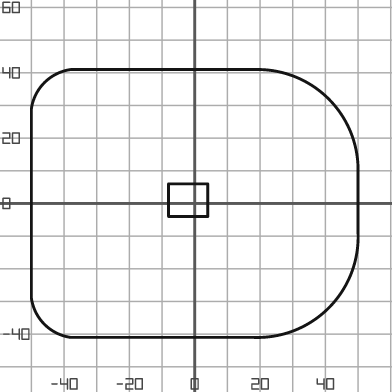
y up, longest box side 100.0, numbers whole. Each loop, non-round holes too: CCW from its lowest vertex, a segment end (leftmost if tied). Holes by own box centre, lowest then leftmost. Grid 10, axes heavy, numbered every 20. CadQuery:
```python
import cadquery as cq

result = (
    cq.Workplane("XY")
    .moveTo(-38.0, -41.0)
    .lineTo(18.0, -41.0)
    .threePointArc((41.0, -32.0), (50.0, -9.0))
    .lineTo(50.0, 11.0)
    .threePointArc((41.0, 32.0), (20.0, 41.0))
    .lineTo(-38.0, 41.0)
    .threePointArc((-46.0, 37.0), (-50.0, 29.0))
    .lineTo(-50.0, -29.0)
    .threePointArc((-46.0, -37.0), (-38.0, -41.0))
    .close()
    .moveTo(-8.0, -4.0)
    .lineTo(4.0, -4.0)
    .lineTo(4.0, 6.0)
    .lineTo(-8.0, 6.0)
    .close()
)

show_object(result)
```